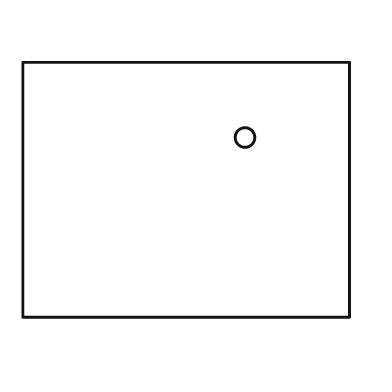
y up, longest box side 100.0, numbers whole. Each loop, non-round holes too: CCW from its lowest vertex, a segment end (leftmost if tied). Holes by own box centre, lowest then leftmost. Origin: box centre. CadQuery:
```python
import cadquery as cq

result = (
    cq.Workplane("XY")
    .moveTo(-50.0, -39.0)
    .lineTo(50.0, -39.0)
    .lineTo(50.0, 39.0)
    .lineTo(-50.0, 39.0)
    .close()
    .moveTo(18.0, 16.0)
    .circle(3.0)
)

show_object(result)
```